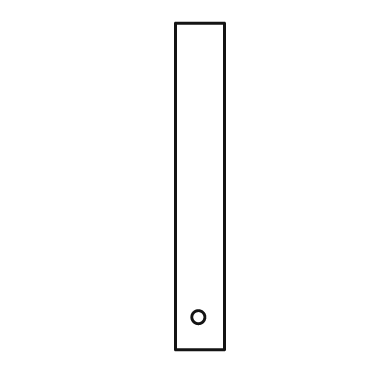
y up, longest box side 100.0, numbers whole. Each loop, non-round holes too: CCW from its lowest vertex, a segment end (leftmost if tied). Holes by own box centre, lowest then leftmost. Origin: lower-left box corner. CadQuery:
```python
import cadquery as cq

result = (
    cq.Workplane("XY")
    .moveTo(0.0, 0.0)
    .lineTo(15.0, 0.0)
    .lineTo(15.0, 100.0)
    .lineTo(0.0, 100.0)
    .close()
    .moveTo(7.0, 10.0)
    .circle(2.0)
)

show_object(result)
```